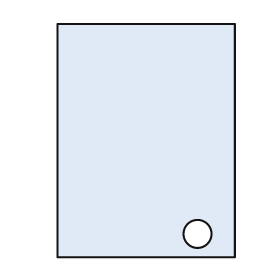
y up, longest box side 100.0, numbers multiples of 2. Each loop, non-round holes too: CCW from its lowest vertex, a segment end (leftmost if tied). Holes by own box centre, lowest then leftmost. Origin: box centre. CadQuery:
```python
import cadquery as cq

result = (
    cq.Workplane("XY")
    .moveTo(-38.0, -50.0)
    .lineTo(38.0, -50.0)
    .lineTo(38.0, 50.0)
    .lineTo(-38.0, 50.0)
    .close()
    .moveTo(22.0, -40.0)
    .circle(6.0)
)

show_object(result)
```